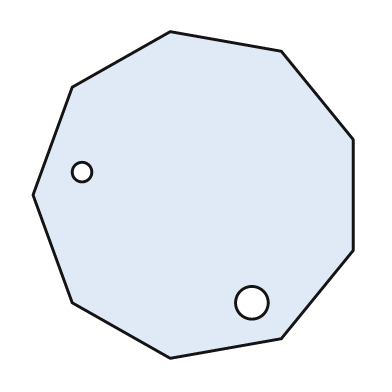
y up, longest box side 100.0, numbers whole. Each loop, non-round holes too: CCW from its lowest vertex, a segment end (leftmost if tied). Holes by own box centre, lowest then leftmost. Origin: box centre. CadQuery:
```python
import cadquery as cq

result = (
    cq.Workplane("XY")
    .moveTo(-7.0, -50.0)
    .lineTo(27.0, -44.0)
    .lineTo(49.0, -17.0)
    .lineTo(49.0, 17.0)
    .lineTo(27.0, 44.0)
    .lineTo(-7.0, 50.0)
    .lineTo(-37.0, 33.0)
    .lineTo(-49.0, 0.0)
    .lineTo(-37.0, -33.0)
    .close()
    .moveTo(18.0, -33.0)
    .circle(5.0)
    .moveTo(-34.0, 7.0)
    .circle(3.0)
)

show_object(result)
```